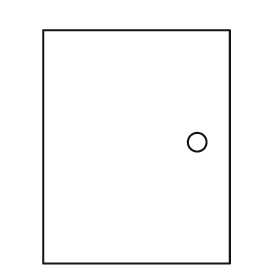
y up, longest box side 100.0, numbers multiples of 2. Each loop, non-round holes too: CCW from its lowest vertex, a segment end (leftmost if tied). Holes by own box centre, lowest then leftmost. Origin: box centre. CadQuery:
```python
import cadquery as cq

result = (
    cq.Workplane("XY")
    .moveTo(-40.0, -50.0)
    .lineTo(40.0, -50.0)
    .lineTo(40.0, 50.0)
    .lineTo(-40.0, 50.0)
    .close()
    .moveTo(26.0, 2.0)
    .circle(4.0)
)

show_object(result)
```